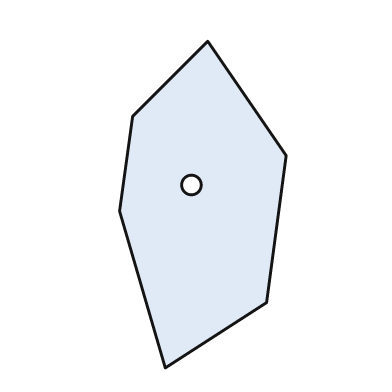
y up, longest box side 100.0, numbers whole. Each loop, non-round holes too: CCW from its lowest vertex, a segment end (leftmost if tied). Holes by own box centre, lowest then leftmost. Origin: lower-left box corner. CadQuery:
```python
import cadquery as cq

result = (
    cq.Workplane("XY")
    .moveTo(14.0, 0.0)
    .lineTo(45.0, 20.0)
    .lineTo(51.0, 65.0)
    .lineTo(27.0, 100.0)
    .lineTo(4.0, 77.0)
    .lineTo(0.0, 48.0)
    .close()
    .moveTo(22.0, 56.0)
    .circle(3.0)
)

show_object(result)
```